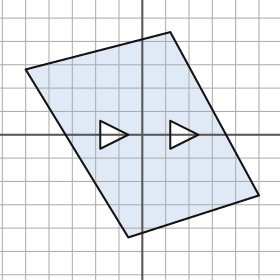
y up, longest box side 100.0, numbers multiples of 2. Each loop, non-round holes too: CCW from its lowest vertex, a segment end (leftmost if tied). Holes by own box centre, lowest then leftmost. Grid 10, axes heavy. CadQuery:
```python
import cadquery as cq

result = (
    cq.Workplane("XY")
    .moveTo(-6.0, -44.0)
    .lineTo(50.0, -26.0)
    .lineTo(12.0, 44.0)
    .lineTo(-50.0, 28.0)
    .close()
    .moveTo(-18.0, -6.0)
    .lineTo(-6.0, 0.0)
    .lineTo(-18.0, 6.0)
    .close()
    .moveTo(12.0, -6.0)
    .lineTo(24.0, 0.0)
    .lineTo(12.0, 6.0)
    .close()
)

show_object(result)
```